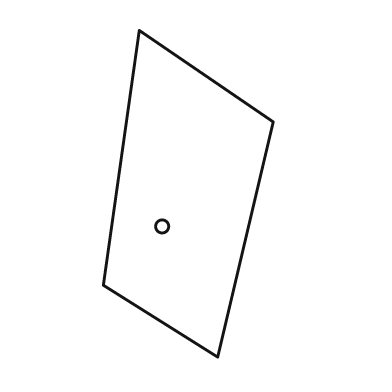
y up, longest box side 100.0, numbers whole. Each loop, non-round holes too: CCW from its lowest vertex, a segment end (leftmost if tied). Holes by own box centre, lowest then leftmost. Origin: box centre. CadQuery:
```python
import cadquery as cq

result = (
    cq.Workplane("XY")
    .moveTo(9.0, -50.0)
    .lineTo(26.0, 22.0)
    .lineTo(-15.0, 50.0)
    .lineTo(-26.0, -28.0)
    .close()
    .moveTo(-8.0, -10.0)
    .circle(2.0)
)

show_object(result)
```